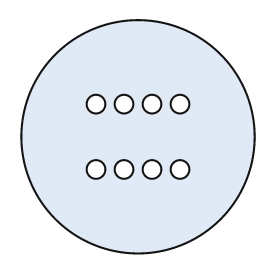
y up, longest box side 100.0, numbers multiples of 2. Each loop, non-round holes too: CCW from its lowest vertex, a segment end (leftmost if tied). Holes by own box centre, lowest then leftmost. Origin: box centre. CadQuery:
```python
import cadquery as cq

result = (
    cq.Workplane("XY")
    .moveTo(0.0, 0.0)
    .circle(50.0)
    .moveTo(-18.0, -14.0)
    .circle(4.0)
    .moveTo(-6.0, -14.0)
    .circle(4.0)
    .moveTo(6.0, -14.0)
    .circle(4.0)
    .moveTo(18.0, -14.0)
    .circle(4.0)
    .moveTo(-18.0, 14.0)
    .circle(4.0)
    .moveTo(-6.0, 14.0)
    .circle(4.0)
    .moveTo(6.0, 14.0)
    .circle(4.0)
    .moveTo(18.0, 14.0)
    .circle(4.0)
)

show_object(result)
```